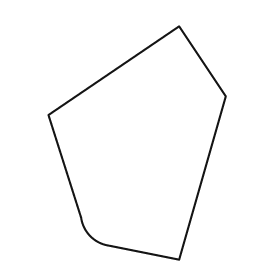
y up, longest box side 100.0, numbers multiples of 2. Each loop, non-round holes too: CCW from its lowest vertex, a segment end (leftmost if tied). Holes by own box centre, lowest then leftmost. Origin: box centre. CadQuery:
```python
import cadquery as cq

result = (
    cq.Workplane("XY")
    .moveTo(18.0, -50.0)
    .lineTo(38.0, 20.0)
    .lineTo(18.0, 50.0)
    .lineTo(-38.0, 12.0)
    .lineTo(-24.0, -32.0)
    .threePointArc((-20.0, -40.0), (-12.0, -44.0))
    .close()
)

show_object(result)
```